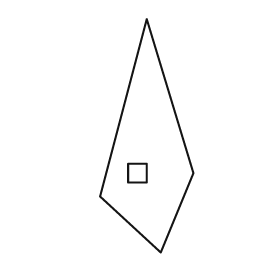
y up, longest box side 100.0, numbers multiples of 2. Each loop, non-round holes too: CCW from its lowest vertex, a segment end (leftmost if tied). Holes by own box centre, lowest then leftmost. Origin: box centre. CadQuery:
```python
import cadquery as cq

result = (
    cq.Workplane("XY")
    .moveTo(6.0, -50.0)
    .lineTo(20.0, -16.0)
    .lineTo(0.0, 50.0)
    .lineTo(-20.0, -26.0)
    .close()
    .moveTo(-8.0, -20.0)
    .lineTo(0.0, -20.0)
    .lineTo(0.0, -12.0)
    .lineTo(-8.0, -12.0)
    .close()
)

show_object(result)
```